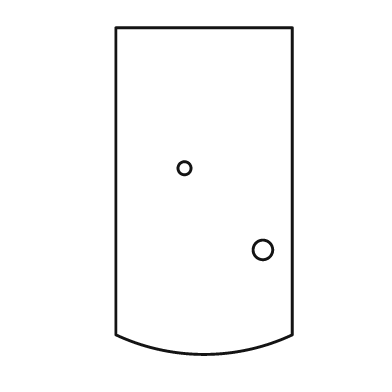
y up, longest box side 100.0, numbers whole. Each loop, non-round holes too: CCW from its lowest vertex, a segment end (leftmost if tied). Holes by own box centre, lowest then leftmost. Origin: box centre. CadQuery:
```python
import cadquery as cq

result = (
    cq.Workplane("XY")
    .moveTo(-27.0, -44.0)
    .threePointArc((0.0, -50.0), (27.0, -44.0))
    .lineTo(27.0, 50.0)
    .lineTo(-27.0, 50.0)
    .close()
    .moveTo(18.0, -18.0)
    .circle(3.0)
    .moveTo(-6.0, 7.0)
    .circle(2.0)
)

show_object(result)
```